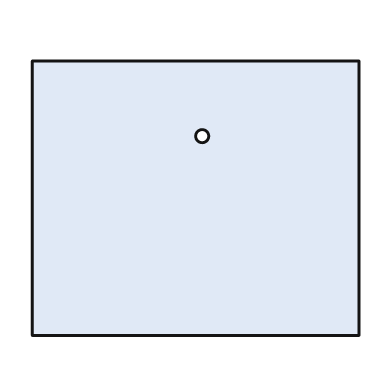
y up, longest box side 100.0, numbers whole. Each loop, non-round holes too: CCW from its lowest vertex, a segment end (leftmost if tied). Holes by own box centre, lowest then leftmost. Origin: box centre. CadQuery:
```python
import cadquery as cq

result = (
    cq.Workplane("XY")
    .moveTo(-50.0, -42.0)
    .lineTo(50.0, -42.0)
    .lineTo(50.0, 42.0)
    .lineTo(-50.0, 42.0)
    .close()
    .moveTo(2.0, 19.0)
    .circle(2.0)
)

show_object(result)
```